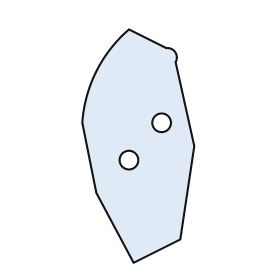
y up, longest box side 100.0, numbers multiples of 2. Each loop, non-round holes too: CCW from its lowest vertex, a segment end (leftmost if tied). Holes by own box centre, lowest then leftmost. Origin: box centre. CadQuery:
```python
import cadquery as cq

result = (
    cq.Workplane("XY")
    .moveTo(-2.0, -50.0)
    .lineTo(18.0, -40.0)
    .lineTo(24.0, 0.0)
    .lineTo(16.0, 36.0)
    .threePointArc((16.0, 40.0), (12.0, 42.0))
    .lineTo(-4.0, 50.0)
    .threePointArc((-18.0, 32.0), (-24.0, 10.0))
    .lineTo(-18.0, -20.0)
    .close()
    .moveTo(-4.0, -6.0)
    .circle(4.0)
    .moveTo(10.0, 10.0)
    .circle(4.0)
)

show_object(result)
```